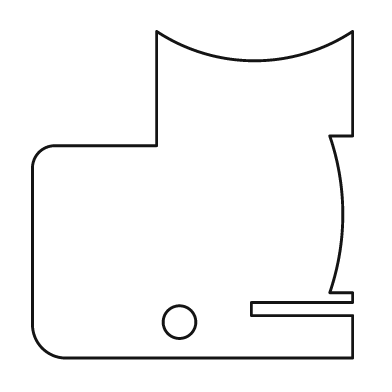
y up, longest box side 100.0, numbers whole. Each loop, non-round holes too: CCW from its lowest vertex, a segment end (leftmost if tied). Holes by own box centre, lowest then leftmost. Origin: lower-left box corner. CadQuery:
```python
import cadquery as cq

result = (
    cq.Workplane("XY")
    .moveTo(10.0, 0.0)
    .lineTo(98.0, 0.0)
    .lineTo(98.0, 13.0)
    .lineTo(67.0, 13.0)
    .lineTo(67.0, 17.0)
    .lineTo(98.0, 17.0)
    .lineTo(98.0, 20.0)
    .lineTo(91.0, 20.0)
    .threePointArc((95.0, 44.0), (91.0, 68.0))
    .lineTo(98.0, 68.0)
    .lineTo(98.0, 100.0)
    .threePointArc((68.0, 91.0), (38.0, 100.0))
    .lineTo(38.0, 65.0)
    .lineTo(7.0, 65.0)
    .threePointArc((2.0, 63.0), (0.0, 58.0))
    .lineTo(0.0, 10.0)
    .threePointArc((3.0, 3.0), (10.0, 0.0))
    .close()
    .moveTo(45.0, 11.0)
    .circle(5.0)
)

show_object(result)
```